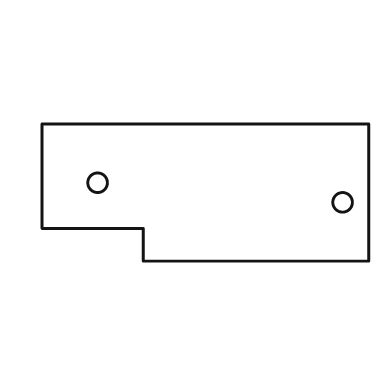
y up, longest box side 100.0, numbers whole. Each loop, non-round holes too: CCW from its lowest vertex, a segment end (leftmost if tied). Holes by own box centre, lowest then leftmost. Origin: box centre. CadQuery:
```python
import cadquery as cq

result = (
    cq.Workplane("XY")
    .moveTo(-19.0, -21.0)
    .lineTo(50.0, -21.0)
    .lineTo(50.0, 21.0)
    .lineTo(-50.0, 21.0)
    .lineTo(-50.0, -11.0)
    .lineTo(-19.0, -11.0)
    .close()
    .moveTo(42.0, -3.0)
    .circle(3.0)
    .moveTo(-33.0, 3.0)
    .circle(3.0)
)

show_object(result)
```